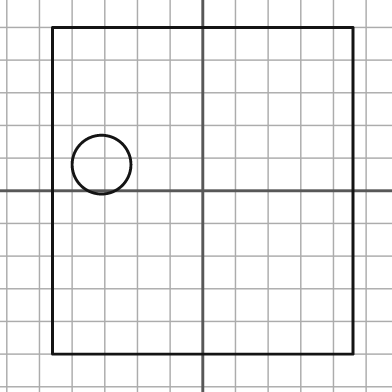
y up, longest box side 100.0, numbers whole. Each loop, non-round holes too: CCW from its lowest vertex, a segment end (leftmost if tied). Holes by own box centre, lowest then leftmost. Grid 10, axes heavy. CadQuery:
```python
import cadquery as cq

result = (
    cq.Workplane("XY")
    .moveTo(-46.0, -50.0)
    .lineTo(46.0, -50.0)
    .lineTo(46.0, 50.0)
    .lineTo(-46.0, 50.0)
    .close()
    .moveTo(-31.0, 8.0)
    .circle(9.0)
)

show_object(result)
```